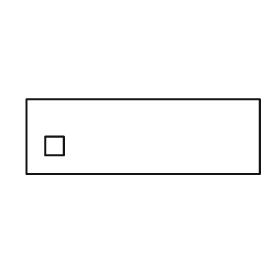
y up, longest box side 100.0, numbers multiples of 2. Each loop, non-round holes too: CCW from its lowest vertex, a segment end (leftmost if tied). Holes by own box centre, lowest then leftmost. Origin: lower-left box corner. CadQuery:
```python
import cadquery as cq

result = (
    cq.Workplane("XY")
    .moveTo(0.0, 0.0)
    .lineTo(100.0, 0.0)
    .lineTo(100.0, 32.0)
    .lineTo(0.0, 32.0)
    .close()
    .moveTo(8.0, 8.0)
    .lineTo(16.0, 8.0)
    .lineTo(16.0, 16.0)
    .lineTo(8.0, 16.0)
    .close()
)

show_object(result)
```